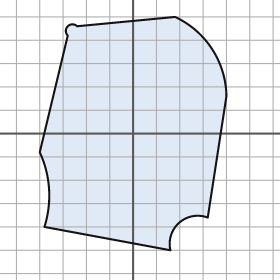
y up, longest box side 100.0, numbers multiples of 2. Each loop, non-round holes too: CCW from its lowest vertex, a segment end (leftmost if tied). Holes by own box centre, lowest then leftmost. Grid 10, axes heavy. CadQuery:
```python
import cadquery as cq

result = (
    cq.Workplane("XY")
    .moveTo(16.0, -50.0)
    .threePointArc((20.0, -38.0), (32.0, -36.0))
    .lineTo(40.0, 16.0)
    .threePointArc((34.0, 36.0), (18.0, 50.0))
    .lineTo(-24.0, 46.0)
    .threePointArc((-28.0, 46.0), (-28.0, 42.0))
    .lineTo(-40.0, -8.0)
    .threePointArc((-36.0, -24.0), (-38.0, -40.0))
    .close()
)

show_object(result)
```